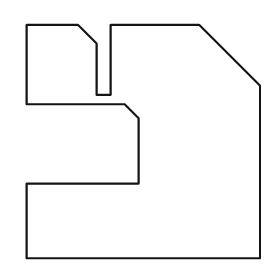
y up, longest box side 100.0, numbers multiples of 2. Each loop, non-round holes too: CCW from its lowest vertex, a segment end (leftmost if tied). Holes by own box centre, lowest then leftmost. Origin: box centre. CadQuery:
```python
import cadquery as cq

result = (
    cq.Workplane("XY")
    .moveTo(-50.0, -50.0)
    .lineTo(50.0, -50.0)
    .lineTo(50.0, 24.0)
    .lineTo(24.0, 50.0)
    .lineTo(-14.0, 50.0)
    .lineTo(-14.0, 20.0)
    .lineTo(-20.0, 20.0)
    .lineTo(-20.0, 42.0)
    .lineTo(-28.0, 50.0)
    .lineTo(-50.0, 50.0)
    .lineTo(-50.0, 16.0)
    .lineTo(-8.0, 16.0)
    .lineTo(-2.0, 10.0)
    .lineTo(-2.0, -18.0)
    .lineTo(-50.0, -18.0)
    .close()
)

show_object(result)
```